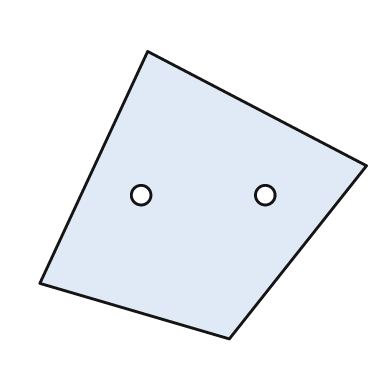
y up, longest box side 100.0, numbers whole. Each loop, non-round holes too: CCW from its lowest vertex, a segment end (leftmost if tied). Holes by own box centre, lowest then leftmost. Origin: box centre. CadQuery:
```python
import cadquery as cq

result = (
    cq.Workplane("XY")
    .moveTo(8.0, -44.0)
    .lineTo(50.0, 9.0)
    .lineTo(-17.0, 44.0)
    .lineTo(-50.0, -27.0)
    .close()
    .moveTo(-19.0, 0.0)
    .circle(3.0)
    .moveTo(19.0, 0.0)
    .circle(3.0)
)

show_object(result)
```